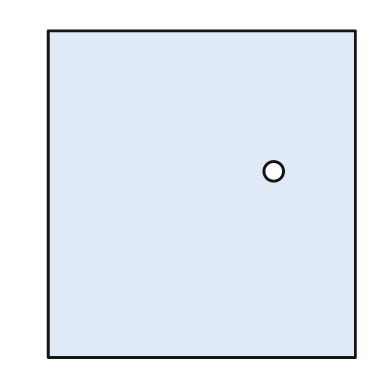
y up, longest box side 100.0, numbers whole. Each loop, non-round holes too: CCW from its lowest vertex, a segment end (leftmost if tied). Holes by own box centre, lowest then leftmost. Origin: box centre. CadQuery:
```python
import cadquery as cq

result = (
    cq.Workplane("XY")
    .moveTo(-47.0, -50.0)
    .lineTo(47.0, -50.0)
    .lineTo(47.0, 50.0)
    .lineTo(-47.0, 50.0)
    .close()
    .moveTo(22.0, 7.0)
    .circle(3.0)
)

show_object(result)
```